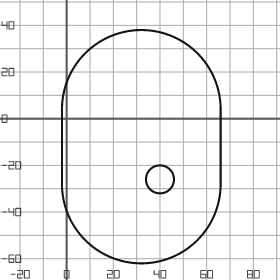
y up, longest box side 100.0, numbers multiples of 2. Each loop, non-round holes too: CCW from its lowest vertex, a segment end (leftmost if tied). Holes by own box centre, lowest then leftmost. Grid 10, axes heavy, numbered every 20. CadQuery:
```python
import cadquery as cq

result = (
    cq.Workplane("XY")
    .moveTo(-2.0, -28.0)
    .threePointArc((32.0, -62.0), (66.0, -28.0))
    .lineTo(66.0, 4.0)
    .threePointArc((32.0, 38.0), (-2.0, 4.0))
    .close()
    .moveTo(40.0, -26.0)
    .circle(6.0)
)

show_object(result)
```